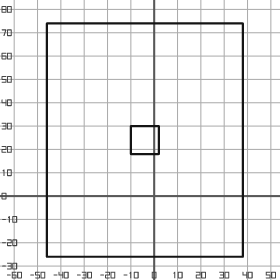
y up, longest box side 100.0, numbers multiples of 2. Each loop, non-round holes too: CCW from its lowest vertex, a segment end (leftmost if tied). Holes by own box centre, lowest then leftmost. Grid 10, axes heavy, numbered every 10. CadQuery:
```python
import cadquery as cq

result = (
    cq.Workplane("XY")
    .moveTo(-46.0, -26.0)
    .lineTo(38.0, -26.0)
    .lineTo(38.0, 74.0)
    .lineTo(-46.0, 74.0)
    .close()
    .moveTo(-10.0, 18.0)
    .lineTo(2.0, 18.0)
    .lineTo(2.0, 30.0)
    .lineTo(-10.0, 30.0)
    .close()
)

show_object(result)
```